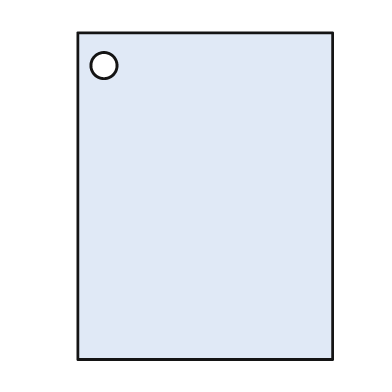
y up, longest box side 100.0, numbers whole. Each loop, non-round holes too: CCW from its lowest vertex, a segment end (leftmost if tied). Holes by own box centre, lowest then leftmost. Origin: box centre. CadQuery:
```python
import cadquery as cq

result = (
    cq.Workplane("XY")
    .moveTo(-39.0, -50.0)
    .lineTo(39.0, -50.0)
    .lineTo(39.0, 50.0)
    .lineTo(-39.0, 50.0)
    .close()
    .moveTo(-31.0, 40.0)
    .circle(4.0)
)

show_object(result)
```